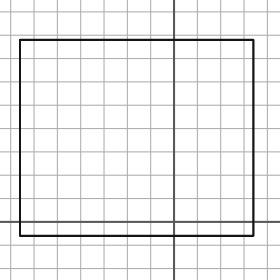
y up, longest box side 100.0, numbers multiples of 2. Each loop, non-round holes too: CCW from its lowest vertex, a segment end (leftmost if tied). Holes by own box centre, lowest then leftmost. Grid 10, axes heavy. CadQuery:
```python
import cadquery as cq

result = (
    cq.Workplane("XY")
    .moveTo(-66.0, -6.0)
    .lineTo(34.0, -6.0)
    .lineTo(34.0, 78.0)
    .lineTo(-66.0, 78.0)
    .close()
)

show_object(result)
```